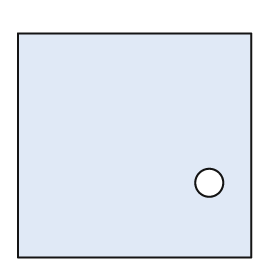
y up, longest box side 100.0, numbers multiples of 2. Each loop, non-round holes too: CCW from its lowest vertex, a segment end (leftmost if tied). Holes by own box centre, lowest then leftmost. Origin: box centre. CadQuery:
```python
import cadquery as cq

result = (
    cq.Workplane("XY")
    .moveTo(-50.0, -48.0)
    .lineTo(50.0, -48.0)
    .lineTo(50.0, 48.0)
    .lineTo(-50.0, 48.0)
    .close()
    .moveTo(32.0, -16.0)
    .circle(6.0)
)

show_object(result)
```